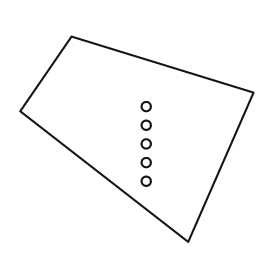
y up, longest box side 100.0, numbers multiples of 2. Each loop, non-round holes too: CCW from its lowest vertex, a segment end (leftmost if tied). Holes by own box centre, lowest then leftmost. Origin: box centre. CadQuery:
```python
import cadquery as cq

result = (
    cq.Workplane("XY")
    .moveTo(22.0, -44.0)
    .lineTo(50.0, 20.0)
    .lineTo(-28.0, 44.0)
    .lineTo(-50.0, 12.0)
    .close()
    .moveTo(4.0, -18.0)
    .circle(2.0)
    .moveTo(4.0, -10.0)
    .circle(2.0)
    .moveTo(4.0, -2.0)
    .circle(2.0)
    .moveTo(4.0, 6.0)
    .circle(2.0)
    .moveTo(4.0, 14.0)
    .circle(2.0)
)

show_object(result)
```